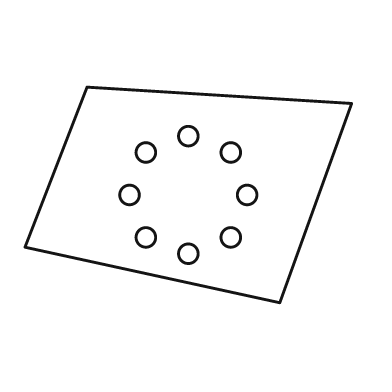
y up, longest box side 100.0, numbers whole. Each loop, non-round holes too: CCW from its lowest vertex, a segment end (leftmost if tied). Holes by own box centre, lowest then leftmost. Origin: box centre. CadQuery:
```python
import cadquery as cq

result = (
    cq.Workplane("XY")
    .moveTo(28.0, -33.0)
    .lineTo(50.0, 28.0)
    .lineTo(-31.0, 33.0)
    .lineTo(-50.0, -16.0)
    .close()
    .moveTo(0.0, -18.0)
    .circle(3.0)
    .moveTo(-13.0, -13.0)
    .circle(3.0)
    .moveTo(13.0, -13.0)
    .circle(3.0)
    .moveTo(-18.0, 0.0)
    .circle(3.0)
    .moveTo(18.0, 0.0)
    .circle(3.0)
    .moveTo(-13.0, 13.0)
    .circle(3.0)
    .moveTo(13.0, 13.0)
    .circle(3.0)
    .moveTo(0.0, 18.0)
    .circle(3.0)
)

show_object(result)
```